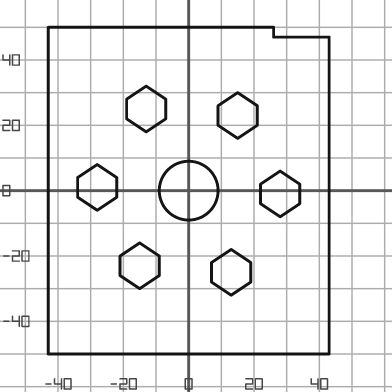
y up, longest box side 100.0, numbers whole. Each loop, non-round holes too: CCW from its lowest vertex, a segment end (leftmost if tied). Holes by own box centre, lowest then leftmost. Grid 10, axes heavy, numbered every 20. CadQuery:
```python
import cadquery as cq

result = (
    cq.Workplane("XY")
    .moveTo(-43.0, -50.0)
    .lineTo(43.0, -50.0)
    .lineTo(43.0, 47.0)
    .lineTo(26.0, 47.0)
    .lineTo(26.0, 50.0)
    .lineTo(-43.0, 50.0)
    .close()
    .moveTo(13.0, -32.0)
    .lineTo(19.0, -28.0)
    .lineTo(19.0, -22.0)
    .lineTo(13.0, -18.0)
    .lineTo(7.0, -22.0)
    .lineTo(7.0, -28.0)
    .close()
    .moveTo(-15.0, -30.0)
    .lineTo(-9.0, -26.0)
    .lineTo(-9.0, -20.0)
    .lineTo(-15.0, -16.0)
    .lineTo(-21.0, -20.0)
    .lineTo(-21.0, -26.0)
    .close()
    .moveTo(28.0, -8.0)
    .lineTo(34.0, -4.0)
    .lineTo(34.0, 2.0)
    .lineTo(28.0, 6.0)
    .lineTo(22.0, 2.0)
    .lineTo(22.0, -4.0)
    .close()
    .moveTo(0.0, 0.0)
    .circle(9.0)
    .moveTo(-28.0, -6.0)
    .lineTo(-22.0, -2.0)
    .lineTo(-22.0, 4.0)
    .lineTo(-28.0, 8.0)
    .lineTo(-34.0, 4.0)
    .lineTo(-34.0, -2.0)
    .close()
    .moveTo(15.0, 16.0)
    .lineTo(21.0, 20.0)
    .lineTo(21.0, 26.0)
    .lineTo(15.0, 30.0)
    .lineTo(9.0, 26.0)
    .lineTo(9.0, 20.0)
    .close()
    .moveTo(-13.0, 18.0)
    .lineTo(-7.0, 22.0)
    .lineTo(-7.0, 28.0)
    .lineTo(-13.0, 32.0)
    .lineTo(-19.0, 28.0)
    .lineTo(-19.0, 22.0)
    .close()
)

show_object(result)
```